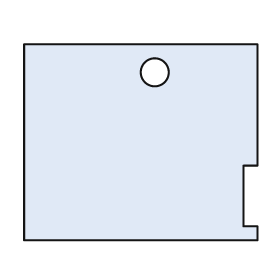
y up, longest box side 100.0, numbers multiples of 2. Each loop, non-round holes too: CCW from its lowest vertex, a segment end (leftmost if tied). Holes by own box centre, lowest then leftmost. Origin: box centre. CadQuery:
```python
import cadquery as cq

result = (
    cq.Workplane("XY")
    .moveTo(-50.0, -42.0)
    .lineTo(50.0, -42.0)
    .lineTo(50.0, -36.0)
    .lineTo(44.0, -36.0)
    .lineTo(44.0, -10.0)
    .lineTo(50.0, -10.0)
    .lineTo(50.0, 42.0)
    .lineTo(-50.0, 42.0)
    .close()
    .moveTo(6.0, 30.0)
    .circle(6.0)
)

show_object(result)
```